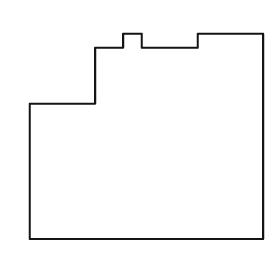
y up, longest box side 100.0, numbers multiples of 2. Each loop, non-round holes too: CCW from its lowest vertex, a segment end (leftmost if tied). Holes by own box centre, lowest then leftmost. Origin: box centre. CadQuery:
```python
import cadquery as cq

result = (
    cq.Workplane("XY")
    .moveTo(-50.0, -44.0)
    .lineTo(50.0, -44.0)
    .lineTo(50.0, 44.0)
    .lineTo(22.0, 44.0)
    .lineTo(22.0, 38.0)
    .lineTo(-2.0, 38.0)
    .lineTo(-2.0, 44.0)
    .lineTo(-10.0, 44.0)
    .lineTo(-10.0, 38.0)
    .lineTo(-22.0, 38.0)
    .lineTo(-22.0, 14.0)
    .lineTo(-50.0, 14.0)
    .close()
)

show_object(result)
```